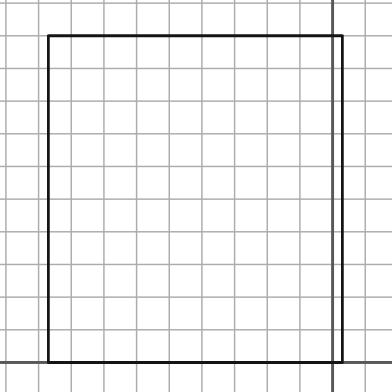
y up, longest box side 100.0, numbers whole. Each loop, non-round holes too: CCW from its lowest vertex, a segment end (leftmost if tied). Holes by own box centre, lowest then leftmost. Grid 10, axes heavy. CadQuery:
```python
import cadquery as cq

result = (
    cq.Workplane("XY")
    .moveTo(-87.0, 0.0)
    .lineTo(3.0, 0.0)
    .lineTo(3.0, 100.0)
    .lineTo(-87.0, 100.0)
    .close()
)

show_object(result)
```